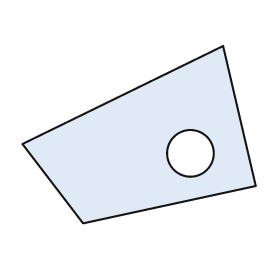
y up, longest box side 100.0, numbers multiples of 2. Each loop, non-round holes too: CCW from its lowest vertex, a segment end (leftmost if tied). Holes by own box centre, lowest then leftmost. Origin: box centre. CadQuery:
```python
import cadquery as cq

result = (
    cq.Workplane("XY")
    .moveTo(-24.0, -38.0)
    .lineTo(50.0, -22.0)
    .lineTo(36.0, 38.0)
    .lineTo(-50.0, -4.0)
    .close()
    .moveTo(22.0, -8.0)
    .circle(10.0)
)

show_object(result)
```